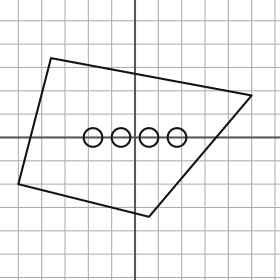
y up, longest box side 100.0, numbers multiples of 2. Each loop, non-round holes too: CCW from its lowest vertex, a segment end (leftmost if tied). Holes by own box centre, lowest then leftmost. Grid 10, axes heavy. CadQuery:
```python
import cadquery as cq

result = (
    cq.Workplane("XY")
    .moveTo(6.0, -34.0)
    .lineTo(50.0, 18.0)
    .lineTo(-36.0, 34.0)
    .lineTo(-50.0, -20.0)
    .close()
    .moveTo(-18.0, 0.0)
    .circle(4.0)
    .moveTo(-6.0, 0.0)
    .circle(4.0)
    .moveTo(6.0, 0.0)
    .circle(4.0)
    .moveTo(18.0, 0.0)
    .circle(4.0)
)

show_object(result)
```